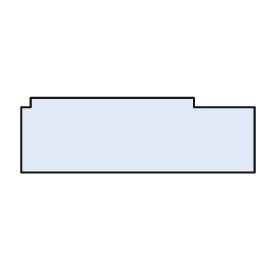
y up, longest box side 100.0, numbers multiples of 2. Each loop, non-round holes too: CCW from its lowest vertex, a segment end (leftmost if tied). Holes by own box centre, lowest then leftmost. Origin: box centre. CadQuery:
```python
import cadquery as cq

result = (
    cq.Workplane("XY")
    .moveTo(-50.0, -16.0)
    .lineTo(50.0, -16.0)
    .lineTo(50.0, 12.0)
    .lineTo(24.0, 12.0)
    .lineTo(24.0, 16.0)
    .lineTo(-46.0, 16.0)
    .lineTo(-46.0, 12.0)
    .lineTo(-50.0, 12.0)
    .close()
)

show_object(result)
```